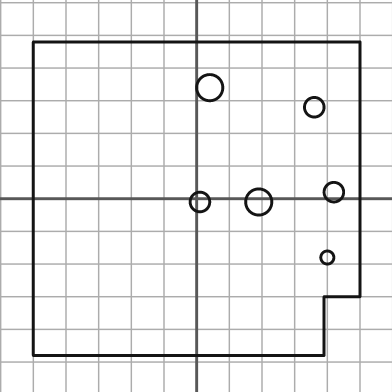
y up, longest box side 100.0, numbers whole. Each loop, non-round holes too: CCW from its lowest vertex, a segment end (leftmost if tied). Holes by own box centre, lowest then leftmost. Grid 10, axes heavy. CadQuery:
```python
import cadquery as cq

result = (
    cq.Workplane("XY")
    .moveTo(-50.0, -48.0)
    .lineTo(39.0, -48.0)
    .lineTo(39.0, -30.0)
    .lineTo(50.0, -30.0)
    .lineTo(50.0, 48.0)
    .lineTo(-50.0, 48.0)
    .close()
    .moveTo(40.0, -18.0)
    .circle(2.0)
    .moveTo(1.0, -1.0)
    .circle(3.0)
    .moveTo(19.0, -1.0)
    .circle(4.0)
    .moveTo(42.0, 2.0)
    .circle(3.0)
    .moveTo(36.0, 28.0)
    .circle(3.0)
    .moveTo(4.0, 34.0)
    .circle(4.0)
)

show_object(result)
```